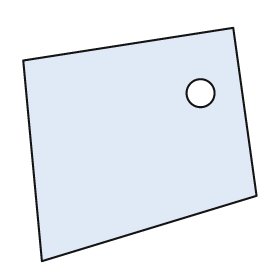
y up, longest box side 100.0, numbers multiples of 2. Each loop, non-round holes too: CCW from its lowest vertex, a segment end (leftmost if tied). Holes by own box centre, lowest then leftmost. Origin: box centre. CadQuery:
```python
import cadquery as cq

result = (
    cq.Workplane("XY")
    .moveTo(-42.0, -50.0)
    .lineTo(50.0, -22.0)
    .lineTo(40.0, 50.0)
    .lineTo(-50.0, 36.0)
    .close()
    .moveTo(26.0, 22.0)
    .circle(6.0)
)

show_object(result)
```